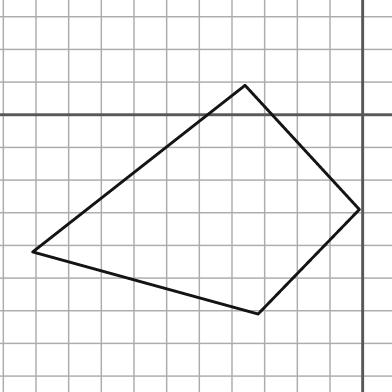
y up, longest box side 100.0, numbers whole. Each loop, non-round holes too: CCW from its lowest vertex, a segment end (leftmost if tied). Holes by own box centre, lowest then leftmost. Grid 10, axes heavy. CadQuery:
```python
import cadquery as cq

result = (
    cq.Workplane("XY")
    .moveTo(-32.0, -61.0)
    .lineTo(-1.0, -29.0)
    .lineTo(-36.0, 9.0)
    .lineTo(-101.0, -42.0)
    .close()
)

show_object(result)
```